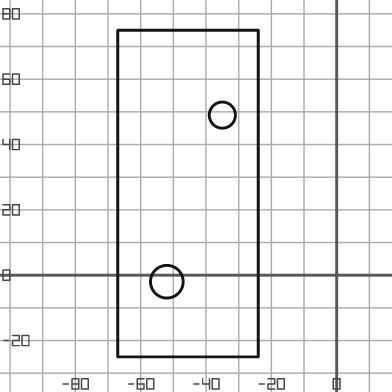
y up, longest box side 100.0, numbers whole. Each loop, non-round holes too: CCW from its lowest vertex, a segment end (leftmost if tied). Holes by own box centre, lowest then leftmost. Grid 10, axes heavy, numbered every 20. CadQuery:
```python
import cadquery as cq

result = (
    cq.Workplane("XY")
    .moveTo(-67.0, -25.0)
    .lineTo(-24.0, -25.0)
    .lineTo(-24.0, 75.0)
    .lineTo(-67.0, 75.0)
    .close()
    .moveTo(-52.0, -2.0)
    .circle(5.0)
    .moveTo(-35.0, 49.0)
    .circle(4.0)
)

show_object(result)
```